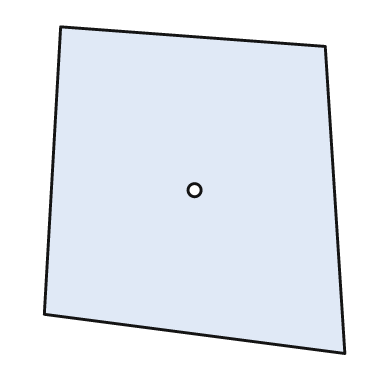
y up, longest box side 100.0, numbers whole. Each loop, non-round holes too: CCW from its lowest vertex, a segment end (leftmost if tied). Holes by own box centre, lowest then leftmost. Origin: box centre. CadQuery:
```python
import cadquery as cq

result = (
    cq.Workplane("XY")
    .moveTo(46.0, -50.0)
    .lineTo(40.0, 44.0)
    .lineTo(-41.0, 50.0)
    .lineTo(-46.0, -38.0)
    .close()
    .moveTo(0.0, 0.0)
    .circle(2.0)
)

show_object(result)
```